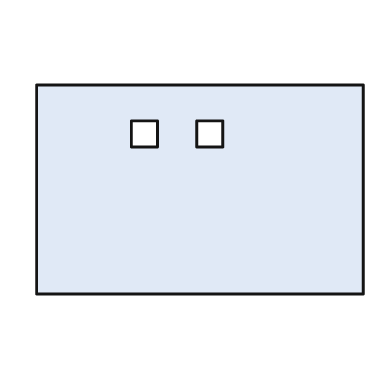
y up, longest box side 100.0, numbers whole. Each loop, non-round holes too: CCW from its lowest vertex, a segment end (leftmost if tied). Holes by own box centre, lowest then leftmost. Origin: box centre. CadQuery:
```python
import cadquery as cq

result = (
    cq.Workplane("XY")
    .moveTo(-50.0, -32.0)
    .lineTo(50.0, -32.0)
    .lineTo(50.0, 32.0)
    .lineTo(-50.0, 32.0)
    .close()
    .moveTo(-21.0, 13.0)
    .lineTo(-13.0, 13.0)
    .lineTo(-13.0, 21.0)
    .lineTo(-21.0, 21.0)
    .close()
    .moveTo(-1.0, 13.0)
    .lineTo(7.0, 13.0)
    .lineTo(7.0, 21.0)
    .lineTo(-1.0, 21.0)
    .close()
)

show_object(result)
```